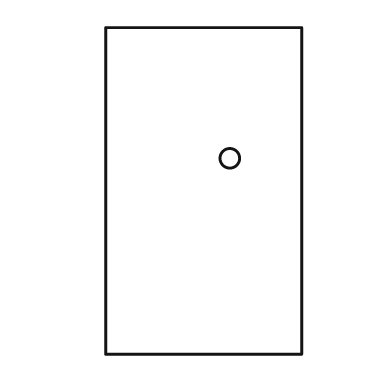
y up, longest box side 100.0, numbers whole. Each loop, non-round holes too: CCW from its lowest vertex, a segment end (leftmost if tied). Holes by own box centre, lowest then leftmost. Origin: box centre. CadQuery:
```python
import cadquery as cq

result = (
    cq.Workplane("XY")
    .moveTo(-30.0, -50.0)
    .lineTo(30.0, -50.0)
    .lineTo(30.0, 50.0)
    .lineTo(-30.0, 50.0)
    .close()
    .moveTo(8.0, 10.0)
    .circle(3.0)
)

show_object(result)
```